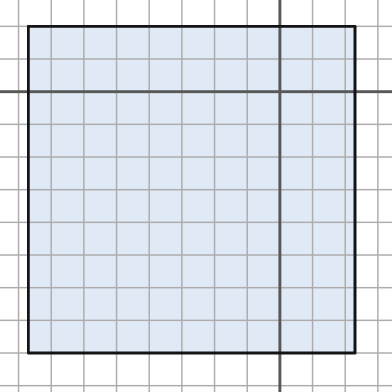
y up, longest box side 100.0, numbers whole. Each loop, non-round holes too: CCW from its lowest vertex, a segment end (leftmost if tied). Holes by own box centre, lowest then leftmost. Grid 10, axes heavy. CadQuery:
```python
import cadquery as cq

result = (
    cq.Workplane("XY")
    .moveTo(-77.0, -80.0)
    .lineTo(23.0, -80.0)
    .lineTo(23.0, 20.0)
    .lineTo(-77.0, 20.0)
    .close()
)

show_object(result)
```